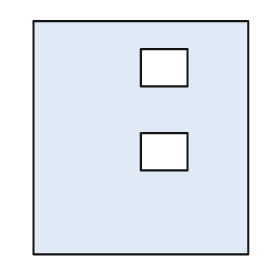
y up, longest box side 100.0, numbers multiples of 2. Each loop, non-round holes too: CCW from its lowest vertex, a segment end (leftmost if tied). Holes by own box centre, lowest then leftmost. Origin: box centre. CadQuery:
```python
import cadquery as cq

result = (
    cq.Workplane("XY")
    .moveTo(-46.0, -50.0)
    .lineTo(46.0, -50.0)
    .lineTo(46.0, 50.0)
    .lineTo(-46.0, 50.0)
    .close()
    .moveTo(0.0, -14.0)
    .lineTo(20.0, -14.0)
    .lineTo(20.0, 2.0)
    .lineTo(0.0, 2.0)
    .close()
    .moveTo(0.0, 22.0)
    .lineTo(20.0, 22.0)
    .lineTo(20.0, 38.0)
    .lineTo(0.0, 38.0)
    .close()
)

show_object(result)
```